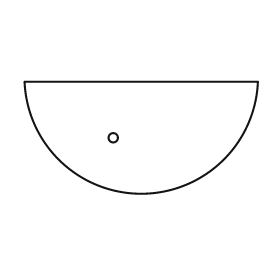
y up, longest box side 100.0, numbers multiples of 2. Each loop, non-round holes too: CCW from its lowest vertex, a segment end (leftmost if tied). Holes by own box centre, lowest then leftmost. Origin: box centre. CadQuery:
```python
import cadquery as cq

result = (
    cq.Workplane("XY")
    .moveTo(-50.0, 24.0)
    .threePointArc((0.0, -24.0), (50.0, 24.0))
    .close()
    .moveTo(-12.0, 0.0)
    .circle(2.0)
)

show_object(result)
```